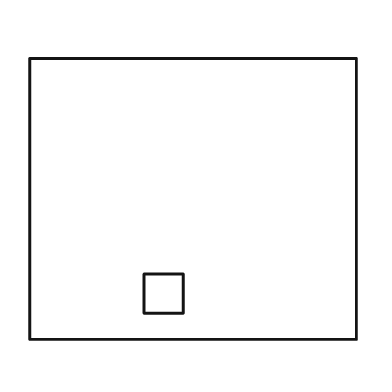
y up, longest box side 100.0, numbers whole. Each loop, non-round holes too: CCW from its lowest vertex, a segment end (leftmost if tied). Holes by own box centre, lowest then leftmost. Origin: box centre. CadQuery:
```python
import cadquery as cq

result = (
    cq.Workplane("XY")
    .moveTo(-50.0, -43.0)
    .lineTo(50.0, -43.0)
    .lineTo(50.0, 43.0)
    .lineTo(-50.0, 43.0)
    .close()
    .moveTo(-15.0, -35.0)
    .lineTo(-3.0, -35.0)
    .lineTo(-3.0, -23.0)
    .lineTo(-15.0, -23.0)
    .close()
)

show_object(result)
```